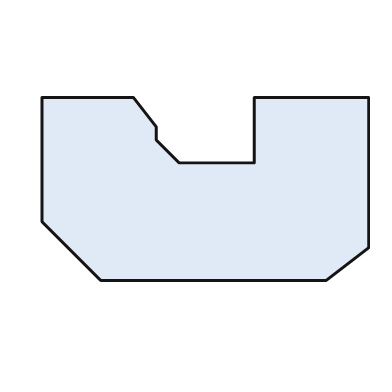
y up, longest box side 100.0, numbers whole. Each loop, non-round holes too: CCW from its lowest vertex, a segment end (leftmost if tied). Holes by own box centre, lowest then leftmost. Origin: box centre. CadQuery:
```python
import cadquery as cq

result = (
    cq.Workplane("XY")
    .moveTo(-32.0, -28.0)
    .lineTo(37.0, -28.0)
    .lineTo(50.0, -18.0)
    .lineTo(50.0, 28.0)
    .lineTo(15.0, 28.0)
    .lineTo(15.0, 8.0)
    .lineTo(-8.0, 8.0)
    .lineTo(-15.0, 15.0)
    .lineTo(-15.0, 19.0)
    .lineTo(-22.0, 28.0)
    .lineTo(-50.0, 28.0)
    .lineTo(-50.0, -10.0)
    .close()
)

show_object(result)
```